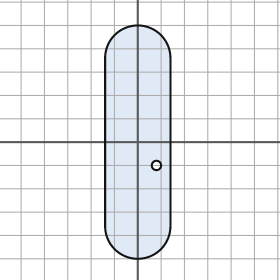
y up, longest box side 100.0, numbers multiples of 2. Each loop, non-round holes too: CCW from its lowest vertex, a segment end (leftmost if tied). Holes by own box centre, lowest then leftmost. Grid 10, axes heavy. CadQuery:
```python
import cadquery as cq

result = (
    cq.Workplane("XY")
    .moveTo(-14.0, -36.0)
    .threePointArc((0.0, -50.0), (14.0, -36.0))
    .lineTo(14.0, 36.0)
    .threePointArc((0.0, 50.0), (-14.0, 36.0))
    .close()
    .moveTo(8.0, -10.0)
    .circle(2.0)
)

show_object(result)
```